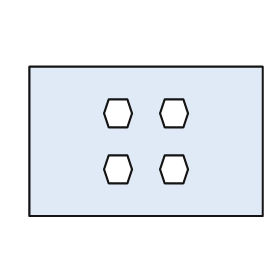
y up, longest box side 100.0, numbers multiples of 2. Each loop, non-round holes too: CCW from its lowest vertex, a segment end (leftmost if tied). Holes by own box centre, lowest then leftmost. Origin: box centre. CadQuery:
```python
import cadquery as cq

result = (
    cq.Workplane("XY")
    .moveTo(-50.0, -32.0)
    .lineTo(50.0, -32.0)
    .lineTo(50.0, 32.0)
    .lineTo(-50.0, 32.0)
    .close()
    .moveTo(-16.0, -18.0)
    .lineTo(-8.0, -18.0)
    .lineTo(-6.0, -12.0)
    .lineTo(-8.0, -6.0)
    .lineTo(-16.0, -6.0)
    .lineTo(-18.0, -12.0)
    .close()
    .moveTo(8.0, -18.0)
    .lineTo(16.0, -18.0)
    .lineTo(18.0, -12.0)
    .lineTo(16.0, -6.0)
    .lineTo(8.0, -6.0)
    .lineTo(6.0, -12.0)
    .close()
    .moveTo(-16.0, 6.0)
    .lineTo(-8.0, 6.0)
    .lineTo(-6.0, 12.0)
    .lineTo(-8.0, 18.0)
    .lineTo(-16.0, 18.0)
    .lineTo(-18.0, 12.0)
    .close()
    .moveTo(8.0, 6.0)
    .lineTo(16.0, 6.0)
    .lineTo(18.0, 12.0)
    .lineTo(16.0, 18.0)
    .lineTo(8.0, 18.0)
    .lineTo(6.0, 12.0)
    .close()
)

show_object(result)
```